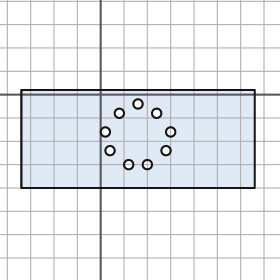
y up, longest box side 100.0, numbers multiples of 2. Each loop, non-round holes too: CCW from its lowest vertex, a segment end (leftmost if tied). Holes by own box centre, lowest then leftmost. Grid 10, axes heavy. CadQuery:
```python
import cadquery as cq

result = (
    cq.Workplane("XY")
    .moveTo(-34.0, -40.0)
    .lineTo(66.0, -40.0)
    .lineTo(66.0, 2.0)
    .lineTo(-34.0, 2.0)
    .close()
    .moveTo(12.0, -30.0)
    .circle(2.0)
    .moveTo(20.0, -30.0)
    .circle(2.0)
    .moveTo(4.0, -24.0)
    .circle(2.0)
    .moveTo(28.0, -24.0)
    .circle(2.0)
    .moveTo(2.0, -16.0)
    .circle(2.0)
    .moveTo(30.0, -16.0)
    .circle(2.0)
    .moveTo(8.0, -8.0)
    .circle(2.0)
    .moveTo(24.0, -8.0)
    .circle(2.0)
    .moveTo(16.0, -4.0)
    .circle(2.0)
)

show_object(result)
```